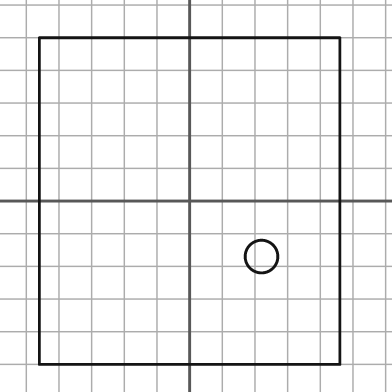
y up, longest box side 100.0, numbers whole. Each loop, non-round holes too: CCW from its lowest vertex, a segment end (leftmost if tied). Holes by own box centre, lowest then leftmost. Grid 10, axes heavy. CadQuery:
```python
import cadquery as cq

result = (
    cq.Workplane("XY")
    .moveTo(-46.0, -50.0)
    .lineTo(46.0, -50.0)
    .lineTo(46.0, 50.0)
    .lineTo(-46.0, 50.0)
    .close()
    .moveTo(22.0, -17.0)
    .circle(5.0)
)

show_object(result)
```